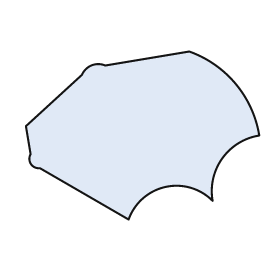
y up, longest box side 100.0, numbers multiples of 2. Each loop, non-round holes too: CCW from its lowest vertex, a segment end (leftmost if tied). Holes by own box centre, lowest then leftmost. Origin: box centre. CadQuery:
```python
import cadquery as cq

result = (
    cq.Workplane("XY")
    .moveTo(-6.0, -36.0)
    .threePointArc((10.0, -22.0), (30.0, -28.0))
    .threePointArc((34.0, -10.0), (50.0, 0.0))
    .threePointArc((40.0, 22.0), (20.0, 36.0))
    .lineTo(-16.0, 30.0)
    .threePointArc((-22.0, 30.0), (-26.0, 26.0))
    .lineTo(-50.0, 4.0)
    .lineTo(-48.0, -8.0)
    .threePointArc((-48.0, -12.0), (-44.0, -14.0))
    .close()
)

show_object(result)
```